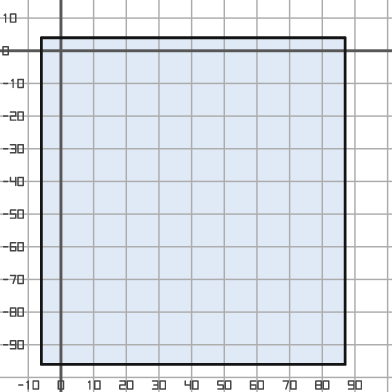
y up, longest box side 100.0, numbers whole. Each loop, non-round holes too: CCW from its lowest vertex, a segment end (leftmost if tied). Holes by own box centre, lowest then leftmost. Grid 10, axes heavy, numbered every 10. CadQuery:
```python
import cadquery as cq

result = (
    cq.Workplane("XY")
    .moveTo(-6.0, -96.0)
    .lineTo(87.0, -96.0)
    .lineTo(87.0, 4.0)
    .lineTo(-6.0, 4.0)
    .close()
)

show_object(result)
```